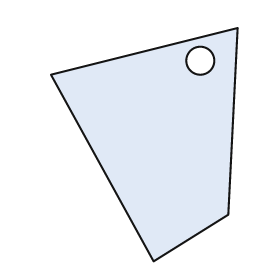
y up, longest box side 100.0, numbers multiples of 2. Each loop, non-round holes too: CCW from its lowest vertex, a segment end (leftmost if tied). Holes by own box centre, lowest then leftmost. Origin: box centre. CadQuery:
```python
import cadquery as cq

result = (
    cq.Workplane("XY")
    .moveTo(4.0, -50.0)
    .lineTo(36.0, -30.0)
    .lineTo(40.0, 50.0)
    .lineTo(-40.0, 30.0)
    .close()
    .moveTo(24.0, 36.0)
    .circle(6.0)
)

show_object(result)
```